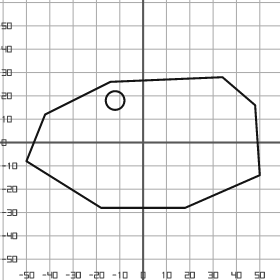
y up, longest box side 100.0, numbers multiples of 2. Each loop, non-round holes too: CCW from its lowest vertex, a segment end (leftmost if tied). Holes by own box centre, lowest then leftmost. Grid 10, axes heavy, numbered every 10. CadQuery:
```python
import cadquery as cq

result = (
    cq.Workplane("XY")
    .moveTo(-18.0, -28.0)
    .lineTo(18.0, -28.0)
    .lineTo(50.0, -14.0)
    .lineTo(48.0, 16.0)
    .lineTo(34.0, 28.0)
    .lineTo(-14.0, 26.0)
    .lineTo(-42.0, 12.0)
    .lineTo(-50.0, -8.0)
    .close()
    .moveTo(-12.0, 18.0)
    .circle(4.0)
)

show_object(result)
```